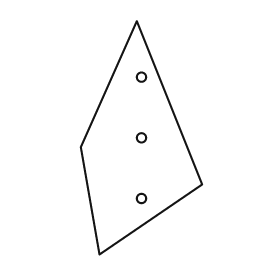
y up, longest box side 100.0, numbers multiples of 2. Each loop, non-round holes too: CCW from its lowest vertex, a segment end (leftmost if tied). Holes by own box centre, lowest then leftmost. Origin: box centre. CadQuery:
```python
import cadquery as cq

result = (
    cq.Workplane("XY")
    .moveTo(-18.0, -50.0)
    .lineTo(26.0, -20.0)
    .lineTo(-2.0, 50.0)
    .lineTo(-26.0, -4.0)
    .close()
    .moveTo(0.0, -26.0)
    .circle(2.0)
    .moveTo(0.0, 0.0)
    .circle(2.0)
    .moveTo(0.0, 26.0)
    .circle(2.0)
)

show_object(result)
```